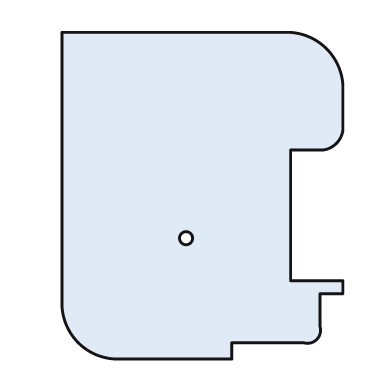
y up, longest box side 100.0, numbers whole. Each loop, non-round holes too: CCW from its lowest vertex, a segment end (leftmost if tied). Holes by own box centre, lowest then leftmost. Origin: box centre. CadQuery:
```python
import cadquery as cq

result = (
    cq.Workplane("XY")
    .moveTo(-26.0, -50.0)
    .lineTo(9.0, -50.0)
    .lineTo(9.0, -45.0)
    .lineTo(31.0, -45.0)
    .threePointArc((35.0, -44.0), (36.0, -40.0))
    .lineTo(36.0, -30.0)
    .lineTo(43.0, -30.0)
    .lineTo(43.0, -26.0)
    .lineTo(27.0, -26.0)
    .lineTo(27.0, 14.0)
    .lineTo(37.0, 14.0)
    .threePointArc((41.0, 16.0), (43.0, 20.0))
    .lineTo(43.0, 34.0)
    .threePointArc((38.0, 45.0), (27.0, 50.0))
    .lineTo(-43.0, 50.0)
    .lineTo(-43.0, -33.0)
    .threePointArc((-38.0, -45.0), (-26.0, -50.0))
    .close()
    .moveTo(-5.0, -13.0)
    .circle(2.0)
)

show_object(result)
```